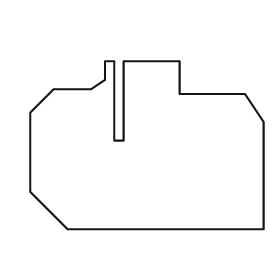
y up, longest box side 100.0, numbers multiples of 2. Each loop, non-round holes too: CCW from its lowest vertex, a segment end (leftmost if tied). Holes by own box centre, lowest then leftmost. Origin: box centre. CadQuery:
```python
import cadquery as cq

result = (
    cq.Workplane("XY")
    .moveTo(-34.0, -36.0)
    .lineTo(50.0, -36.0)
    .lineTo(50.0, 10.0)
    .lineTo(42.0, 22.0)
    .lineTo(14.0, 22.0)
    .lineTo(14.0, 36.0)
    .lineTo(-10.0, 36.0)
    .lineTo(-10.0, 2.0)
    .lineTo(-14.0, 2.0)
    .lineTo(-14.0, 36.0)
    .lineTo(-18.0, 36.0)
    .lineTo(-18.0, 28.0)
    .lineTo(-24.0, 24.0)
    .lineTo(-40.0, 24.0)
    .lineTo(-50.0, 14.0)
    .lineTo(-50.0, -20.0)
    .close()
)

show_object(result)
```